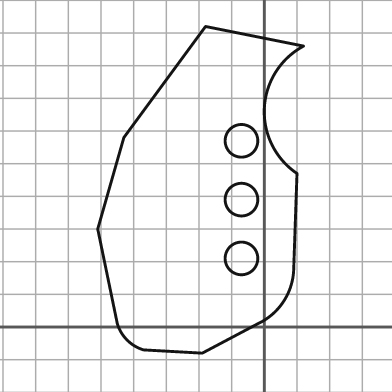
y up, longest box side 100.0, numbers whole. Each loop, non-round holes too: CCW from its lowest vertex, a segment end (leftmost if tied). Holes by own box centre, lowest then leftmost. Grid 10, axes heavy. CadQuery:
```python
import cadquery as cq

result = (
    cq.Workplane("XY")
    .moveTo(-19.0, -8.0)
    .lineTo(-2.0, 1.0)
    .threePointArc((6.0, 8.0), (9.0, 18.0))
    .lineTo(10.0, 47.0)
    .threePointArc((0.0, 67.0), (12.0, 86.0))
    .lineTo(-18.0, 92.0)
    .lineTo(-43.0, 58.0)
    .lineTo(-51.0, 30.0)
    .lineTo(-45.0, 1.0)
    .threePointArc((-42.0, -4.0), (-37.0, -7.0))
    .close()
    .moveTo(-7.0, 21.0)
    .circle(5.0)
    .moveTo(-7.0, 39.0)
    .circle(5.0)
    .moveTo(-7.0, 57.0)
    .circle(5.0)
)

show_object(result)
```